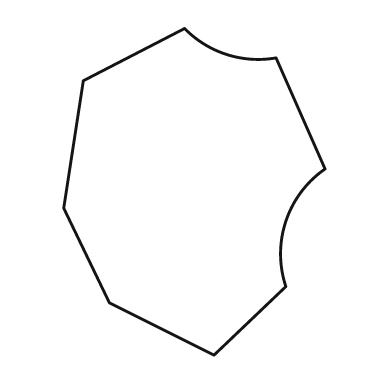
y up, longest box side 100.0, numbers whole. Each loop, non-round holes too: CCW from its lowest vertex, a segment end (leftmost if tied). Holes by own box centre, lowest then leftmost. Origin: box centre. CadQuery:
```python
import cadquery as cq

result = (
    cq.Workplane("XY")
    .moveTo(6.0, -50.0)
    .lineTo(28.0, -29.0)
    .threePointArc((28.0, -9.0), (40.0, 7.0))
    .lineTo(25.0, 41.0)
    .threePointArc((10.0, 42.0), (-3.0, 50.0))
    .lineTo(-34.0, 34.0)
    .lineTo(-40.0, -5.0)
    .lineTo(-26.0, -34.0)
    .close()
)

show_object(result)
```